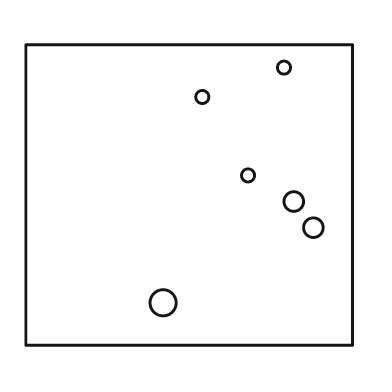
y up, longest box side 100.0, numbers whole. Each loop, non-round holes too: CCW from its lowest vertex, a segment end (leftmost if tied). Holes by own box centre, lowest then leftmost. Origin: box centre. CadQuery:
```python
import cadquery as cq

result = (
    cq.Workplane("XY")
    .moveTo(-50.0, -46.0)
    .lineTo(50.0, -46.0)
    .lineTo(50.0, 46.0)
    .lineTo(-50.0, 46.0)
    .close()
    .moveTo(-8.0, -33.0)
    .circle(4.0)
    .moveTo(38.0, -10.0)
    .circle(3.0)
    .moveTo(32.0, -2.0)
    .circle(3.0)
    .moveTo(18.0, 6.0)
    .circle(2.0)
    .moveTo(4.0, 30.0)
    .circle(2.0)
    .moveTo(29.0, 39.0)
    .circle(2.0)
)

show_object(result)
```